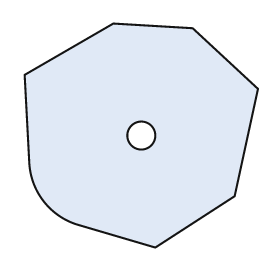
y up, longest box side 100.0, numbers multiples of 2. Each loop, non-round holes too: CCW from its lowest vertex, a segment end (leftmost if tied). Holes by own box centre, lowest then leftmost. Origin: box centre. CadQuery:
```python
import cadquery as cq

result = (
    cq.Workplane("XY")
    .moveTo(6.0, -48.0)
    .lineTo(40.0, -26.0)
    .lineTo(50.0, 20.0)
    .lineTo(22.0, 46.0)
    .lineTo(-12.0, 48.0)
    .lineTo(-50.0, 26.0)
    .lineTo(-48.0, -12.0)
    .threePointArc((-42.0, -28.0), (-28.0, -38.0))
    .close()
    .moveTo(0.0, 0.0)
    .circle(6.0)
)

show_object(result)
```